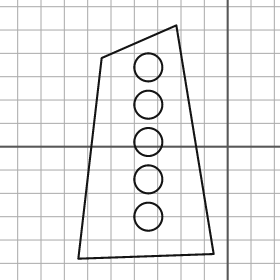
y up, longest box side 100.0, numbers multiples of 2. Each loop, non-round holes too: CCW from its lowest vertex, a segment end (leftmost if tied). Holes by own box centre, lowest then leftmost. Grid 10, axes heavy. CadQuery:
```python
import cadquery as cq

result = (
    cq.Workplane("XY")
    .moveTo(-64.0, -48.0)
    .lineTo(-6.0, -46.0)
    .lineTo(-22.0, 52.0)
    .lineTo(-54.0, 38.0)
    .close()
    .moveTo(-34.0, -30.0)
    .circle(6.0)
    .moveTo(-34.0, -14.0)
    .circle(6.0)
    .moveTo(-34.0, 2.0)
    .circle(6.0)
    .moveTo(-34.0, 18.0)
    .circle(6.0)
    .moveTo(-34.0, 34.0)
    .circle(6.0)
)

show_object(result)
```